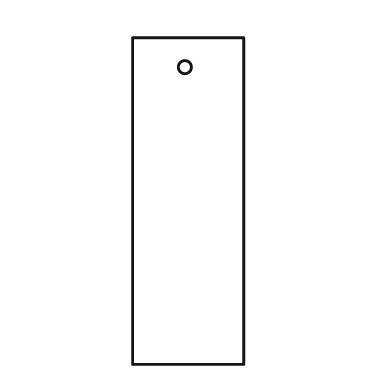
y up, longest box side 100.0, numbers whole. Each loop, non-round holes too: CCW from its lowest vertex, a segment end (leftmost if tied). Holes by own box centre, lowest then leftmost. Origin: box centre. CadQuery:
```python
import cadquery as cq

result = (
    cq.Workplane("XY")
    .moveTo(-17.0, -50.0)
    .lineTo(17.0, -50.0)
    .lineTo(17.0, 50.0)
    .lineTo(-17.0, 50.0)
    .close()
    .moveTo(-1.0, 41.0)
    .circle(2.0)
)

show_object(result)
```